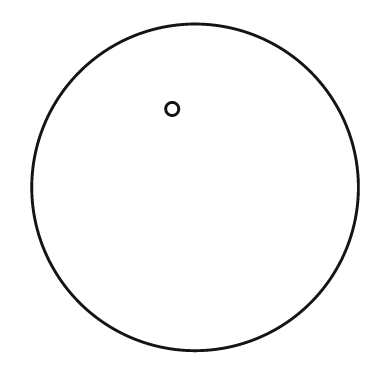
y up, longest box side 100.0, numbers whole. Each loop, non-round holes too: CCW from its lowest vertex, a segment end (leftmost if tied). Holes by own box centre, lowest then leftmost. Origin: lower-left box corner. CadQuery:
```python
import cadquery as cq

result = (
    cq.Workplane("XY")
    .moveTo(50.0, 50.0)
    .circle(50.0)
    .moveTo(43.0, 74.0)
    .circle(2.0)
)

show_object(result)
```